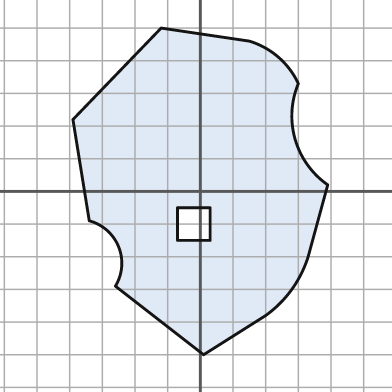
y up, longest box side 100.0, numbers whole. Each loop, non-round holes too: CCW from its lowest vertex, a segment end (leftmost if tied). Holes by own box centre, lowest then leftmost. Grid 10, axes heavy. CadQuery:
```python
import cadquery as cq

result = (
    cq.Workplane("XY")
    .moveTo(1.0, -50.0)
    .lineTo(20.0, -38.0)
    .threePointArc((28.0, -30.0), (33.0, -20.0))
    .lineTo(39.0, 2.0)
    .threePointArc((29.0, 16.0), (30.0, 33.0))
    .threePointArc((24.0, 41.0), (15.0, 46.0))
    .lineTo(-12.0, 50.0)
    .lineTo(-39.0, 22.0)
    .lineTo(-34.0, -9.0)
    .threePointArc((-25.0, -17.0), (-26.0, -29.0))
    .close()
    .moveTo(-7.0, -15.0)
    .lineTo(3.0, -15.0)
    .lineTo(3.0, -5.0)
    .lineTo(-7.0, -5.0)
    .close()
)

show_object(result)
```